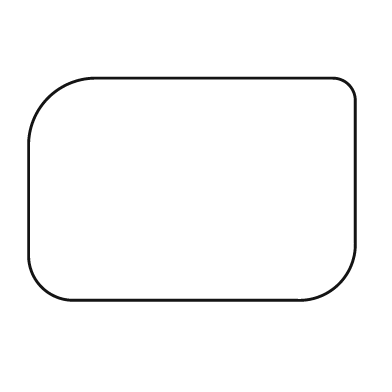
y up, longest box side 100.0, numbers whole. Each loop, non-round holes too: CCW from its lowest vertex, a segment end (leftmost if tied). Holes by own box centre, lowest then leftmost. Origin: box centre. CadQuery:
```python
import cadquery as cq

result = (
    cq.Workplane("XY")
    .moveTo(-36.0, -34.0)
    .lineTo(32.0, -34.0)
    .threePointArc((45.0, -29.0), (50.0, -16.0))
    .lineTo(50.0, 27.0)
    .threePointArc((48.0, 32.0), (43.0, 34.0))
    .lineTo(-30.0, 34.0)
    .threePointArc((-44.0, 28.0), (-50.0, 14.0))
    .lineTo(-50.0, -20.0)
    .threePointArc((-46.0, -30.0), (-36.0, -34.0))
    .close()
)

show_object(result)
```